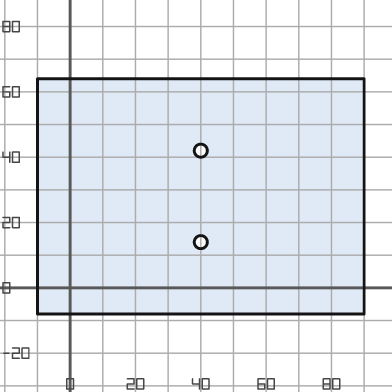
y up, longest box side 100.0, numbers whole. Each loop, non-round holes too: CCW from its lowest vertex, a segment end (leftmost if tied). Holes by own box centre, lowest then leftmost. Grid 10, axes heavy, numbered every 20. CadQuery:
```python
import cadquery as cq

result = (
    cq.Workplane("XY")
    .moveTo(-10.0, -8.0)
    .lineTo(90.0, -8.0)
    .lineTo(90.0, 64.0)
    .lineTo(-10.0, 64.0)
    .close()
    .moveTo(40.0, 14.0)
    .circle(2.0)
    .moveTo(40.0, 42.0)
    .circle(2.0)
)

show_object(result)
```